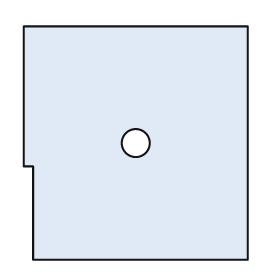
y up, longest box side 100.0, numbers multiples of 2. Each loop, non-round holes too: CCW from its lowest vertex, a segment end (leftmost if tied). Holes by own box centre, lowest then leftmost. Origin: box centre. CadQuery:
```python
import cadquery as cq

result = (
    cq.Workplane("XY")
    .moveTo(-44.0, -50.0)
    .lineTo(48.0, -50.0)
    .lineTo(48.0, 50.0)
    .lineTo(-48.0, 50.0)
    .lineTo(-48.0, -10.0)
    .lineTo(-44.0, -10.0)
    .close()
    .moveTo(0.0, 0.0)
    .circle(6.0)
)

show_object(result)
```